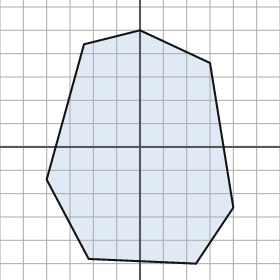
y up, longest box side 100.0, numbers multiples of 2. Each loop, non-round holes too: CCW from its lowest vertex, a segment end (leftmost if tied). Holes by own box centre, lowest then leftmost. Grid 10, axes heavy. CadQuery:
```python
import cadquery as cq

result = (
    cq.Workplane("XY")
    .moveTo(24.0, -50.0)
    .lineTo(40.0, -26.0)
    .lineTo(30.0, 36.0)
    .lineTo(0.0, 50.0)
    .lineTo(-24.0, 44.0)
    .lineTo(-40.0, -14.0)
    .lineTo(-22.0, -48.0)
    .close()
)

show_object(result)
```